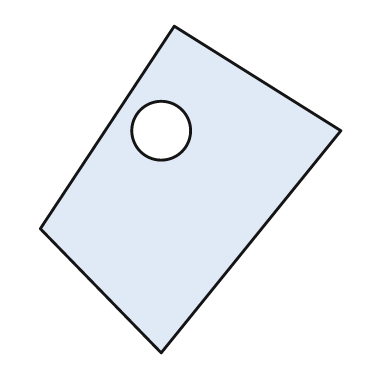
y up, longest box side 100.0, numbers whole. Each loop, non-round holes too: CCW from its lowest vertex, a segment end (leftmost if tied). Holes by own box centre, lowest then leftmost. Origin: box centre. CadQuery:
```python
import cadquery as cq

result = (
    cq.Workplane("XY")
    .moveTo(-9.0, -50.0)
    .lineTo(46.0, 18.0)
    .lineTo(-5.0, 50.0)
    .lineTo(-46.0, -12.0)
    .close()
    .moveTo(-9.0, 18.0)
    .circle(9.0)
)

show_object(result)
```